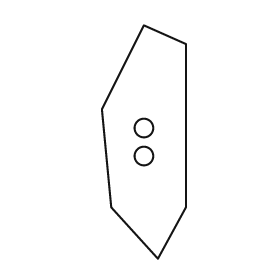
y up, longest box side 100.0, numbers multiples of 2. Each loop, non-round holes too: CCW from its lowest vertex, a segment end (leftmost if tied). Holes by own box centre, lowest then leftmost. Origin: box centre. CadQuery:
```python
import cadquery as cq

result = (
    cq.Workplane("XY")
    .moveTo(6.0, -50.0)
    .lineTo(18.0, -28.0)
    .lineTo(18.0, 42.0)
    .lineTo(0.0, 50.0)
    .lineTo(-18.0, 14.0)
    .lineTo(-14.0, -28.0)
    .close()
    .moveTo(0.0, -6.0)
    .circle(4.0)
    .moveTo(0.0, 6.0)
    .circle(4.0)
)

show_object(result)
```